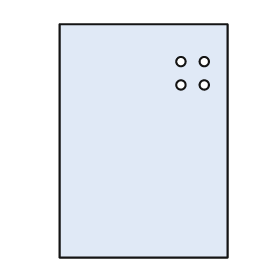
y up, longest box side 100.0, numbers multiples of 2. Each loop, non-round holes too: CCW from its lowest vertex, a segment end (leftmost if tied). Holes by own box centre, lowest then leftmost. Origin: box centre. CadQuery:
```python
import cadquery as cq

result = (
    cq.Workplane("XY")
    .moveTo(-36.0, -50.0)
    .lineTo(36.0, -50.0)
    .lineTo(36.0, 50.0)
    .lineTo(-36.0, 50.0)
    .close()
    .moveTo(16.0, 24.0)
    .circle(2.0)
    .moveTo(26.0, 24.0)
    .circle(2.0)
    .moveTo(16.0, 34.0)
    .circle(2.0)
    .moveTo(26.0, 34.0)
    .circle(2.0)
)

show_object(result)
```